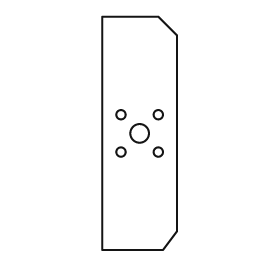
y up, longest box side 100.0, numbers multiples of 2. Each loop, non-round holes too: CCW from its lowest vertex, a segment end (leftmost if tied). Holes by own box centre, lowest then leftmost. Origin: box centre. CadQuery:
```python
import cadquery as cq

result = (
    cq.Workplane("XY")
    .moveTo(-16.0, -50.0)
    .lineTo(10.0, -50.0)
    .lineTo(16.0, -42.0)
    .lineTo(16.0, 42.0)
    .lineTo(8.0, 50.0)
    .lineTo(-16.0, 50.0)
    .close()
    .moveTo(-8.0, -8.0)
    .circle(2.0)
    .moveTo(8.0, -8.0)
    .circle(2.0)
    .moveTo(0.0, 0.0)
    .circle(4.0)
    .moveTo(-8.0, 8.0)
    .circle(2.0)
    .moveTo(8.0, 8.0)
    .circle(2.0)
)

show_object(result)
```